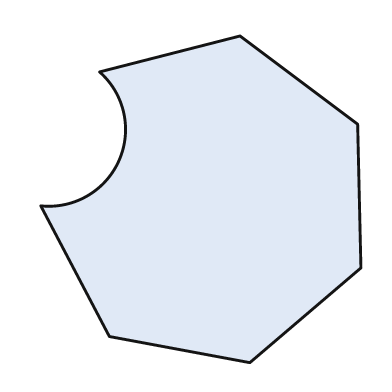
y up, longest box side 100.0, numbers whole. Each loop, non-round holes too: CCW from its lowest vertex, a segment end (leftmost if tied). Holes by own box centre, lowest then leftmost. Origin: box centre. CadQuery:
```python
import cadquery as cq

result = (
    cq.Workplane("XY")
    .moveTo(15.0, -50.0)
    .lineTo(49.0, -21.0)
    .lineTo(48.0, 23.0)
    .lineTo(12.0, 50.0)
    .lineTo(-31.0, 39.0)
    .threePointArc((-25.0, 12.0), (-49.0, -2.0))
    .lineTo(-28.0, -42.0)
    .close()
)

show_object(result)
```